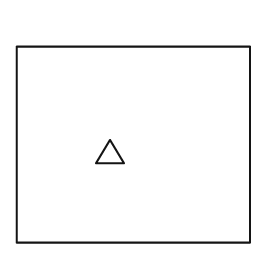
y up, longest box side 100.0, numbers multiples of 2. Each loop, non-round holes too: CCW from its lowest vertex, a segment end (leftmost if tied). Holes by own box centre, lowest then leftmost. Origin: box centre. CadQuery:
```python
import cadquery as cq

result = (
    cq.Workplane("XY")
    .moveTo(-50.0, -42.0)
    .lineTo(50.0, -42.0)
    .lineTo(50.0, 42.0)
    .lineTo(-50.0, 42.0)
    .close()
    .moveTo(-16.0, -8.0)
    .lineTo(-4.0, -8.0)
    .lineTo(-10.0, 2.0)
    .close()
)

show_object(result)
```